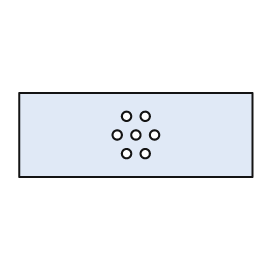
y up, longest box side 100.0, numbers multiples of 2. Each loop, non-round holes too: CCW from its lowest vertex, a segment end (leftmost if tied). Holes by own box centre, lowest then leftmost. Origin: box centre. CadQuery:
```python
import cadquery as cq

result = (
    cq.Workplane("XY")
    .moveTo(-50.0, -18.0)
    .lineTo(50.0, -18.0)
    .lineTo(50.0, 18.0)
    .lineTo(-50.0, 18.0)
    .close()
    .moveTo(-4.0, -8.0)
    .circle(2.0)
    .moveTo(4.0, -8.0)
    .circle(2.0)
    .moveTo(-8.0, 0.0)
    .circle(2.0)
    .moveTo(0.0, 0.0)
    .circle(2.0)
    .moveTo(8.0, 0.0)
    .circle(2.0)
    .moveTo(-4.0, 8.0)
    .circle(2.0)
    .moveTo(4.0, 8.0)
    .circle(2.0)
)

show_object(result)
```